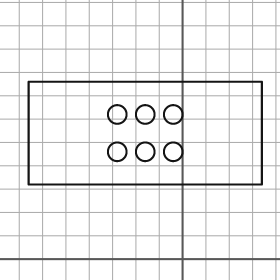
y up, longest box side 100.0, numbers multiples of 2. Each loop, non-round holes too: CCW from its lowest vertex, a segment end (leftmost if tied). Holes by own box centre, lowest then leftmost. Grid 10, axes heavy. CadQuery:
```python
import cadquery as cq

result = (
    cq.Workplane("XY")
    .moveTo(-66.0, 32.0)
    .lineTo(34.0, 32.0)
    .lineTo(34.0, 76.0)
    .lineTo(-66.0, 76.0)
    .close()
    .moveTo(-28.0, 46.0)
    .circle(4.0)
    .moveTo(-16.0, 46.0)
    .circle(4.0)
    .moveTo(-4.0, 46.0)
    .circle(4.0)
    .moveTo(-28.0, 62.0)
    .circle(4.0)
    .moveTo(-16.0, 62.0)
    .circle(4.0)
    .moveTo(-4.0, 62.0)
    .circle(4.0)
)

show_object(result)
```